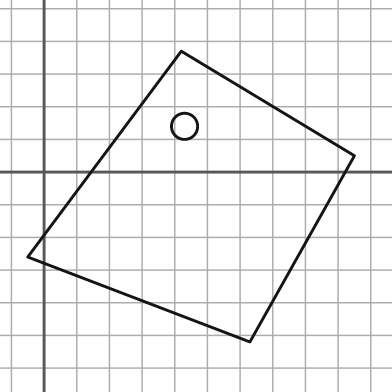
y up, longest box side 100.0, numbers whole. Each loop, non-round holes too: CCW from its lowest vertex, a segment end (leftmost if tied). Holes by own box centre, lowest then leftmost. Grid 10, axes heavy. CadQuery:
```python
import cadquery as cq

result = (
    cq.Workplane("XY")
    .moveTo(63.0, -52.0)
    .lineTo(95.0, 5.0)
    .lineTo(42.0, 37.0)
    .lineTo(-5.0, -26.0)
    .close()
    .moveTo(43.0, 14.0)
    .circle(4.0)
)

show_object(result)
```